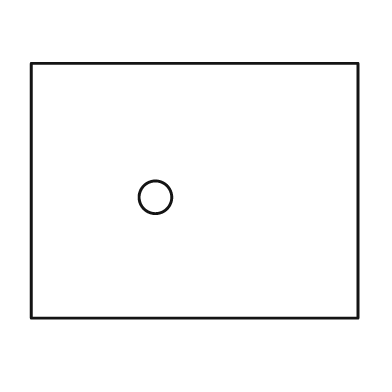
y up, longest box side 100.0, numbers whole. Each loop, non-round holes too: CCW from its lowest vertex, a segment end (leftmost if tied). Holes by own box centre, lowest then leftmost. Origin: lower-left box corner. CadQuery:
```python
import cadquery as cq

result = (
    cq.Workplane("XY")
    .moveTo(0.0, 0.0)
    .lineTo(100.0, 0.0)
    .lineTo(100.0, 78.0)
    .lineTo(0.0, 78.0)
    .close()
    .moveTo(38.0, 37.0)
    .circle(5.0)
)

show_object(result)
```